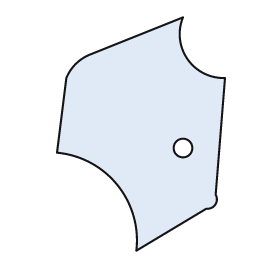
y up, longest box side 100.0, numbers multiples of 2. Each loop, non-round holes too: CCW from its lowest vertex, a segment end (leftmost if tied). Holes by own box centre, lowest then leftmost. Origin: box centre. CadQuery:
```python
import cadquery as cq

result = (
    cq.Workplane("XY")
    .moveTo(-2.0, -50.0)
    .lineTo(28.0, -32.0)
    .threePointArc((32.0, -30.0), (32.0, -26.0))
    .lineTo(36.0, 24.0)
    .threePointArc((20.0, 32.0), (18.0, 50.0))
    .lineTo(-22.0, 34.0)
    .threePointArc((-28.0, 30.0), (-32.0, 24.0))
    .lineTo(-36.0, -8.0)
    .threePointArc((-10.0, -22.0), (-2.0, -50.0))
    .close()
    .moveTo(18.0, -6.0)
    .circle(4.0)
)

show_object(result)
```